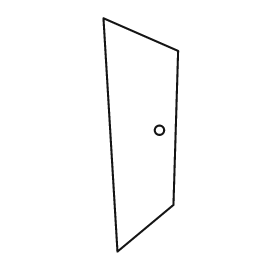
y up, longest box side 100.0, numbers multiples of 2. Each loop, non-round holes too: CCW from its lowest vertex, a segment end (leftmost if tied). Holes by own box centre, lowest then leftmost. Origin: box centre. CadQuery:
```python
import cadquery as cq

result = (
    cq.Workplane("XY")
    .moveTo(-10.0, -50.0)
    .lineTo(14.0, -30.0)
    .lineTo(16.0, 36.0)
    .lineTo(-16.0, 50.0)
    .close()
    .moveTo(8.0, 2.0)
    .circle(2.0)
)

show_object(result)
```